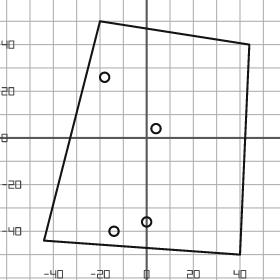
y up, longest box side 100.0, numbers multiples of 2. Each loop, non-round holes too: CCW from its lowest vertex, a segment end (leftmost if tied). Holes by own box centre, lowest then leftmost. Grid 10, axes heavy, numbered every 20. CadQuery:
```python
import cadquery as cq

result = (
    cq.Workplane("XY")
    .moveTo(40.0, -50.0)
    .lineTo(44.0, 40.0)
    .lineTo(-20.0, 50.0)
    .lineTo(-44.0, -44.0)
    .close()
    .moveTo(-14.0, -40.0)
    .circle(2.0)
    .moveTo(0.0, -36.0)
    .circle(2.0)
    .moveTo(4.0, 4.0)
    .circle(2.0)
    .moveTo(-18.0, 26.0)
    .circle(2.0)
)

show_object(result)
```